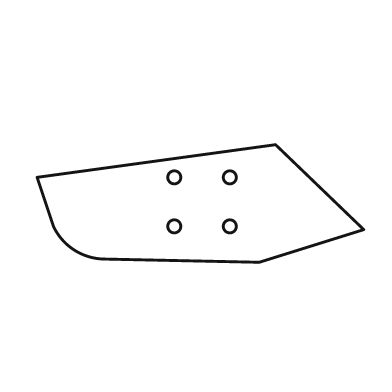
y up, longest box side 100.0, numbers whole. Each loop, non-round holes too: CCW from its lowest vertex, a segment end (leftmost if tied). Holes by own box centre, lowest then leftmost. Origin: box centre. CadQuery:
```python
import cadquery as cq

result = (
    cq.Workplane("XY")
    .moveTo(18.0, -18.0)
    .lineTo(50.0, -8.0)
    .lineTo(23.0, 18.0)
    .lineTo(-50.0, 8.0)
    .lineTo(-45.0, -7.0)
    .threePointArc((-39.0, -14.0), (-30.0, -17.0))
    .close()
    .moveTo(-8.0, -7.0)
    .circle(2.0)
    .moveTo(9.0, -7.0)
    .circle(2.0)
    .moveTo(-8.0, 8.0)
    .circle(2.0)
    .moveTo(9.0, 8.0)
    .circle(2.0)
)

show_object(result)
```